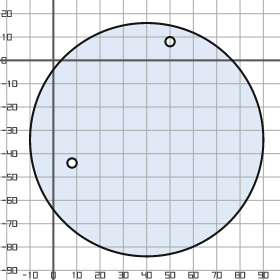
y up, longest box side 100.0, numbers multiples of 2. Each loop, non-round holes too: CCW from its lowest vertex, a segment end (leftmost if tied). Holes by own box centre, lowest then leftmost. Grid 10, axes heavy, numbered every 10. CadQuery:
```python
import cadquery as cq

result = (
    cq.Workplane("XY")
    .moveTo(40.0, -34.0)
    .circle(50.0)
    .moveTo(8.0, -44.0)
    .circle(2.0)
    .moveTo(50.0, 8.0)
    .circle(2.0)
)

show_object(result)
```